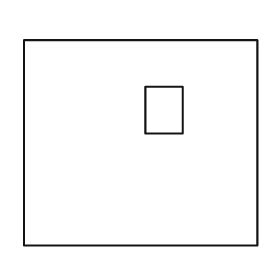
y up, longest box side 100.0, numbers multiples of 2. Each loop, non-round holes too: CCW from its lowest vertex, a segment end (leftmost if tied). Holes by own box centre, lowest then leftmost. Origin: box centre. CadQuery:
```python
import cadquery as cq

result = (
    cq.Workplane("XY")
    .moveTo(-50.0, -44.0)
    .lineTo(50.0, -44.0)
    .lineTo(50.0, 44.0)
    .lineTo(-50.0, 44.0)
    .close()
    .moveTo(2.0, 4.0)
    .lineTo(18.0, 4.0)
    .lineTo(18.0, 24.0)
    .lineTo(2.0, 24.0)
    .close()
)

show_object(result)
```